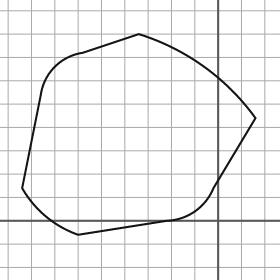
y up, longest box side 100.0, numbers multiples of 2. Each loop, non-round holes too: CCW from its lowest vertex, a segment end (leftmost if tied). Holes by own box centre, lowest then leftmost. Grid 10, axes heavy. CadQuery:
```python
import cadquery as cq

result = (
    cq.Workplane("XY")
    .moveTo(-60.0, -6.0)
    .lineTo(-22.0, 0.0)
    .threePointArc((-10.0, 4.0), (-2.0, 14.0))
    .lineTo(16.0, 44.0)
    .threePointArc((-6.0, 66.0), (-34.0, 80.0))
    .lineTo(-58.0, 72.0)
    .threePointArc((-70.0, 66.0), (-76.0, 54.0))
    .lineTo(-84.0, 14.0)
    .threePointArc((-74.0, 2.0), (-60.0, -6.0))
    .close()
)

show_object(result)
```